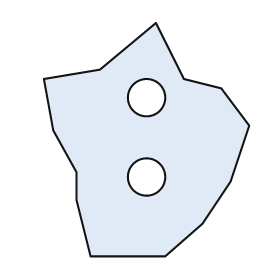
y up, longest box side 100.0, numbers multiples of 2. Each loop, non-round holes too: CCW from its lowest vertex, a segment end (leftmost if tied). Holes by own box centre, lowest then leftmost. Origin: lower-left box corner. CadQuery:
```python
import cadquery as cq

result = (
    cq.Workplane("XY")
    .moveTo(20.0, 0.0)
    .lineTo(52.0, 0.0)
    .lineTo(68.0, 14.0)
    .lineTo(80.0, 32.0)
    .lineTo(88.0, 56.0)
    .lineTo(76.0, 72.0)
    .lineTo(60.0, 76.0)
    .lineTo(48.0, 100.0)
    .lineTo(24.0, 80.0)
    .lineTo(0.0, 76.0)
    .lineTo(4.0, 54.0)
    .lineTo(14.0, 36.0)
    .lineTo(14.0, 24.0)
    .close()
    .moveTo(44.0, 34.0)
    .circle(8.0)
    .moveTo(44.0, 68.0)
    .circle(8.0)
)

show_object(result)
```